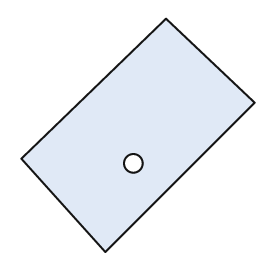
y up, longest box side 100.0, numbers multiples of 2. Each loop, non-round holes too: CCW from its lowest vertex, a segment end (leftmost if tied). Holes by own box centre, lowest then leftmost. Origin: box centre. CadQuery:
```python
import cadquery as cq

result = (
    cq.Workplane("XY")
    .moveTo(-14.0, -50.0)
    .lineTo(50.0, 14.0)
    .lineTo(12.0, 50.0)
    .lineTo(-50.0, -10.0)
    .close()
    .moveTo(-2.0, -12.0)
    .circle(4.0)
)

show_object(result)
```